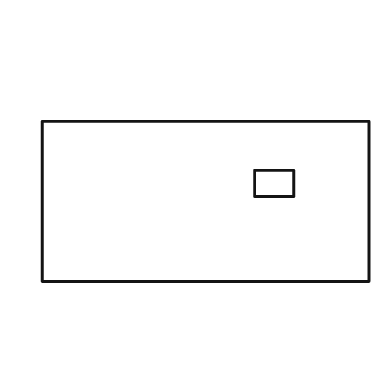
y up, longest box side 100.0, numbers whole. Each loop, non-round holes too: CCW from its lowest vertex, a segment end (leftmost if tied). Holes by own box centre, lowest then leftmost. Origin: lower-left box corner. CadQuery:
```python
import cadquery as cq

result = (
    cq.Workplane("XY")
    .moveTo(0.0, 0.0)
    .lineTo(100.0, 0.0)
    .lineTo(100.0, 49.0)
    .lineTo(0.0, 49.0)
    .close()
    .moveTo(65.0, 26.0)
    .lineTo(77.0, 26.0)
    .lineTo(77.0, 34.0)
    .lineTo(65.0, 34.0)
    .close()
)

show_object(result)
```